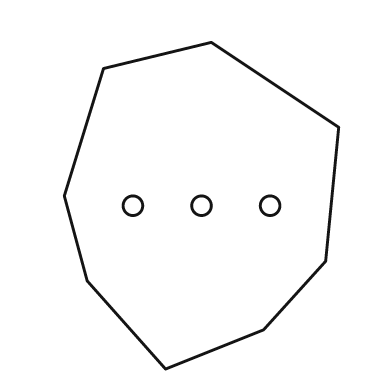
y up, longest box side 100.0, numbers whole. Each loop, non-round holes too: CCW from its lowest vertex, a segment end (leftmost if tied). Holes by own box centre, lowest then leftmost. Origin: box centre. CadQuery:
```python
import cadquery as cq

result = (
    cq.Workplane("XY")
    .moveTo(-11.0, -50.0)
    .lineTo(19.0, -38.0)
    .lineTo(38.0, -17.0)
    .lineTo(42.0, 24.0)
    .lineTo(3.0, 50.0)
    .lineTo(-30.0, 42.0)
    .lineTo(-42.0, 3.0)
    .lineTo(-35.0, -23.0)
    .close()
    .moveTo(-21.0, 0.0)
    .circle(3.0)
    .moveTo(0.0, 0.0)
    .circle(3.0)
    .moveTo(21.0, 0.0)
    .circle(3.0)
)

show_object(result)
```